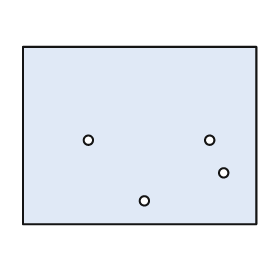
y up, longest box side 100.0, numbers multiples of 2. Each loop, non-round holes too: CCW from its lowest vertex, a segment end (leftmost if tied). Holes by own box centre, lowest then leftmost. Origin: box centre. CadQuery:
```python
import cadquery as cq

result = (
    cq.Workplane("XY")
    .moveTo(-50.0, -38.0)
    .lineTo(50.0, -38.0)
    .lineTo(50.0, 38.0)
    .lineTo(-50.0, 38.0)
    .close()
    .moveTo(2.0, -28.0)
    .circle(2.0)
    .moveTo(36.0, -16.0)
    .circle(2.0)
    .moveTo(-22.0, -2.0)
    .circle(2.0)
    .moveTo(30.0, -2.0)
    .circle(2.0)
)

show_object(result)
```